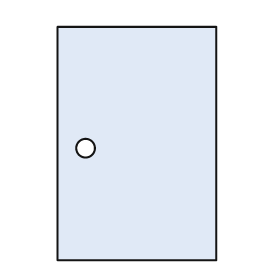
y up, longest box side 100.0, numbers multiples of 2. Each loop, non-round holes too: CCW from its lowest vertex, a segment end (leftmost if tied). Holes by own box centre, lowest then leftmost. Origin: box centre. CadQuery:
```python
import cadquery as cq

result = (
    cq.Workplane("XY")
    .moveTo(-34.0, -50.0)
    .lineTo(34.0, -50.0)
    .lineTo(34.0, 50.0)
    .lineTo(-34.0, 50.0)
    .close()
    .moveTo(-22.0, -2.0)
    .circle(4.0)
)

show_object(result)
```